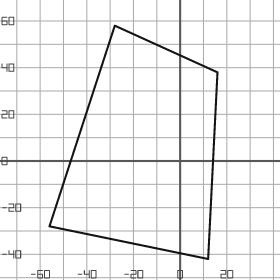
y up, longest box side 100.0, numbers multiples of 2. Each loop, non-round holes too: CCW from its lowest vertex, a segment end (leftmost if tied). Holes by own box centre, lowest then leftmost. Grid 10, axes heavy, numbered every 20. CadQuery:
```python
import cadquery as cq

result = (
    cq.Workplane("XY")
    .moveTo(12.0, -42.0)
    .lineTo(16.0, 38.0)
    .lineTo(-28.0, 58.0)
    .lineTo(-56.0, -28.0)
    .close()
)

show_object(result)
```